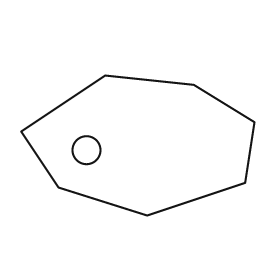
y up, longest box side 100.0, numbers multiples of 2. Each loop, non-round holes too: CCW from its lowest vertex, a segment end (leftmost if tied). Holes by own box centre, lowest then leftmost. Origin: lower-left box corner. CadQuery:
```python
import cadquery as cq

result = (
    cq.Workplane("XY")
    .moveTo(54.0, 0.0)
    .lineTo(96.0, 14.0)
    .lineTo(100.0, 40.0)
    .lineTo(74.0, 56.0)
    .lineTo(36.0, 60.0)
    .lineTo(0.0, 36.0)
    .lineTo(16.0, 12.0)
    .close()
    .moveTo(28.0, 28.0)
    .circle(6.0)
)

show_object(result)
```